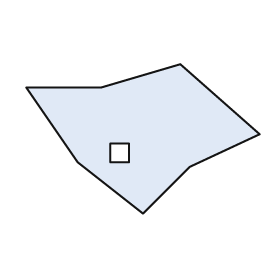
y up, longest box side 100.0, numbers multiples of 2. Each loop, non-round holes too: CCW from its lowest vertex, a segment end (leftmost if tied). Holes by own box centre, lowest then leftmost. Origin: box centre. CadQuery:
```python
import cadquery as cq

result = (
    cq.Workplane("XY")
    .moveTo(0.0, -32.0)
    .lineTo(20.0, -12.0)
    .lineTo(50.0, 2.0)
    .lineTo(16.0, 32.0)
    .lineTo(-18.0, 22.0)
    .lineTo(-50.0, 22.0)
    .lineTo(-28.0, -10.0)
    .close()
    .moveTo(-14.0, -10.0)
    .lineTo(-6.0, -10.0)
    .lineTo(-6.0, -2.0)
    .lineTo(-14.0, -2.0)
    .close()
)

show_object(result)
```